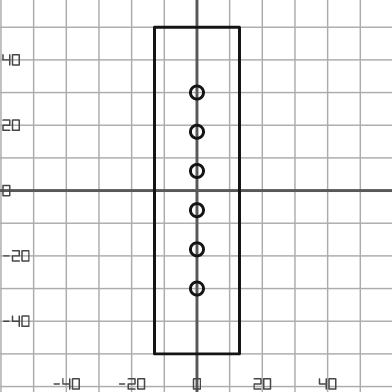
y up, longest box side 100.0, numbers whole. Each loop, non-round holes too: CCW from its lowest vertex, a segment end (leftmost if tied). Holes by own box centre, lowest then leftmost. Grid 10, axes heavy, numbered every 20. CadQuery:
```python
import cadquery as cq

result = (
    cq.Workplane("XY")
    .moveTo(-13.0, -50.0)
    .lineTo(13.0, -50.0)
    .lineTo(13.0, 50.0)
    .lineTo(-13.0, 50.0)
    .close()
    .moveTo(0.0, -30.0)
    .circle(2.0)
    .moveTo(0.0, -18.0)
    .circle(2.0)
    .moveTo(0.0, -6.0)
    .circle(2.0)
    .moveTo(0.0, 6.0)
    .circle(2.0)
    .moveTo(0.0, 18.0)
    .circle(2.0)
    .moveTo(0.0, 30.0)
    .circle(2.0)
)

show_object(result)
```